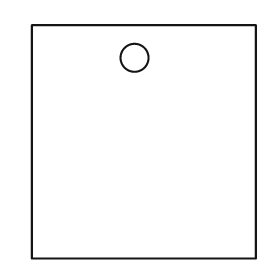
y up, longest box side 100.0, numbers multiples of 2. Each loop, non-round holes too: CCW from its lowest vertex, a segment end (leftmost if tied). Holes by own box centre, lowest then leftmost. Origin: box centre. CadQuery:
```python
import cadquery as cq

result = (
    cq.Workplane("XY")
    .moveTo(-48.0, -50.0)
    .lineTo(48.0, -50.0)
    .lineTo(48.0, 50.0)
    .lineTo(-48.0, 50.0)
    .close()
    .moveTo(-4.0, 36.0)
    .circle(6.0)
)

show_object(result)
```